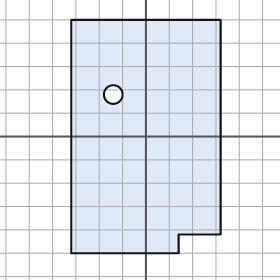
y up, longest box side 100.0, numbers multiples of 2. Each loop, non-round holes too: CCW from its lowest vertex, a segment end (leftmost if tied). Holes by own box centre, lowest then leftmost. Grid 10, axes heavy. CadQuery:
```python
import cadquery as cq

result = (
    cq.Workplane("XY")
    .moveTo(-32.0, -50.0)
    .lineTo(14.0, -50.0)
    .lineTo(14.0, -42.0)
    .lineTo(32.0, -42.0)
    .lineTo(32.0, 50.0)
    .lineTo(-32.0, 50.0)
    .close()
    .moveTo(-14.0, 18.0)
    .circle(4.0)
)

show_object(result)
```